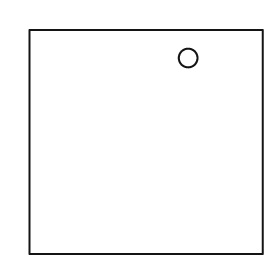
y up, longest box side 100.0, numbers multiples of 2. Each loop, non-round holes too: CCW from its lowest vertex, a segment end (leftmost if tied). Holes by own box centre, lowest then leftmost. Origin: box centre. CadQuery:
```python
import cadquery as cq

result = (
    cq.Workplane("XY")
    .moveTo(-50.0, -48.0)
    .lineTo(50.0, -48.0)
    .lineTo(50.0, 48.0)
    .lineTo(-50.0, 48.0)
    .close()
    .moveTo(18.0, 36.0)
    .circle(4.0)
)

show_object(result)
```